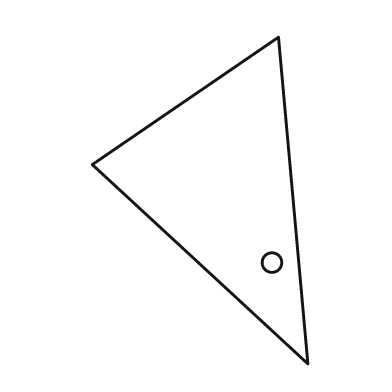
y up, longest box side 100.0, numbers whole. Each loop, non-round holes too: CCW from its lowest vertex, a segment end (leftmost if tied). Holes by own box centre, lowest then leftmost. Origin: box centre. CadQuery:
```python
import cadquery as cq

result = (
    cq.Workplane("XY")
    .moveTo(33.0, -50.0)
    .lineTo(24.0, 50.0)
    .lineTo(-33.0, 11.0)
    .close()
    .moveTo(22.0, -19.0)
    .circle(3.0)
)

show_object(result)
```